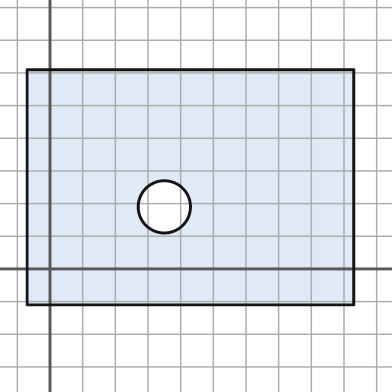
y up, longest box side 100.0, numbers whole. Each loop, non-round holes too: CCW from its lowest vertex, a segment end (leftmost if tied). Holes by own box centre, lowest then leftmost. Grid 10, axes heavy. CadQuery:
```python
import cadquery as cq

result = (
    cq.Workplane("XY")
    .moveTo(-7.0, -11.0)
    .lineTo(93.0, -11.0)
    .lineTo(93.0, 61.0)
    .lineTo(-7.0, 61.0)
    .close()
    .moveTo(35.0, 19.0)
    .circle(8.0)
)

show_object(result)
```